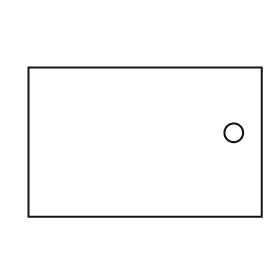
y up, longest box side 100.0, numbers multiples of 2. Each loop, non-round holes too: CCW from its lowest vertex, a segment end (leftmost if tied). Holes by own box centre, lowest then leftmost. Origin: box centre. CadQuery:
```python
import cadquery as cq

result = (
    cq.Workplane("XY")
    .moveTo(-50.0, -32.0)
    .lineTo(50.0, -32.0)
    .lineTo(50.0, 32.0)
    .lineTo(-50.0, 32.0)
    .close()
    .moveTo(38.0, 4.0)
    .circle(4.0)
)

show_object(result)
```